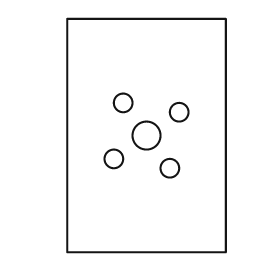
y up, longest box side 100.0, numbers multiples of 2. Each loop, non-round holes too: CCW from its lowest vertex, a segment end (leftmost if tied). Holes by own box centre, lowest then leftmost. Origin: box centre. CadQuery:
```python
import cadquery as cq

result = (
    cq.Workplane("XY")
    .moveTo(-34.0, -50.0)
    .lineTo(34.0, -50.0)
    .lineTo(34.0, 50.0)
    .lineTo(-34.0, 50.0)
    .close()
    .moveTo(10.0, -14.0)
    .circle(4.0)
    .moveTo(-14.0, -10.0)
    .circle(4.0)
    .moveTo(0.0, 0.0)
    .circle(6.0)
    .moveTo(14.0, 10.0)
    .circle(4.0)
    .moveTo(-10.0, 14.0)
    .circle(4.0)
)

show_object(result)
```